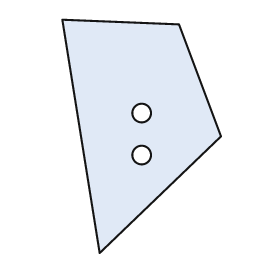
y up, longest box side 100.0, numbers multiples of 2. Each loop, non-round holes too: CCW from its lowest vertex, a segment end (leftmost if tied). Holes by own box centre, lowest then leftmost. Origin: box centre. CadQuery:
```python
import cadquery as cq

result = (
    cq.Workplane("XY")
    .moveTo(-18.0, -50.0)
    .lineTo(34.0, 0.0)
    .lineTo(16.0, 48.0)
    .lineTo(-34.0, 50.0)
    .close()
    .moveTo(0.0, -8.0)
    .circle(4.0)
    .moveTo(0.0, 10.0)
    .circle(4.0)
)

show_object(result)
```